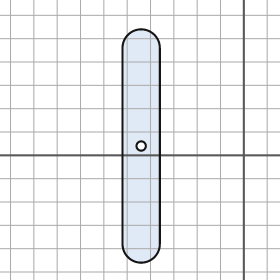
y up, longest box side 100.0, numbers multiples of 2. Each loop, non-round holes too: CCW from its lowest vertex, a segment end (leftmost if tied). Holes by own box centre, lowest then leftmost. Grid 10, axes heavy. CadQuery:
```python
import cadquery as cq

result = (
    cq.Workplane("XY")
    .moveTo(-52.0, -38.0)
    .threePointArc((-44.0, -46.0), (-36.0, -38.0))
    .lineTo(-36.0, 46.0)
    .threePointArc((-44.0, 54.0), (-52.0, 46.0))
    .close()
    .moveTo(-44.0, 4.0)
    .circle(2.0)
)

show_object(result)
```